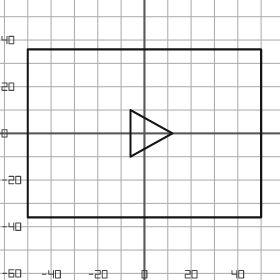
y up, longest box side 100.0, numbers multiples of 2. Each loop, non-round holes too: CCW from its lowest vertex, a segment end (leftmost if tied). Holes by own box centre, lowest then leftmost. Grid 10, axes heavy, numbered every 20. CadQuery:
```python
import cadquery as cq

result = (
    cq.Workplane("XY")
    .moveTo(-50.0, -36.0)
    .lineTo(50.0, -36.0)
    .lineTo(50.0, 36.0)
    .lineTo(-50.0, 36.0)
    .close()
    .moveTo(-6.0, -10.0)
    .lineTo(12.0, 0.0)
    .lineTo(-6.0, 10.0)
    .close()
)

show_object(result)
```